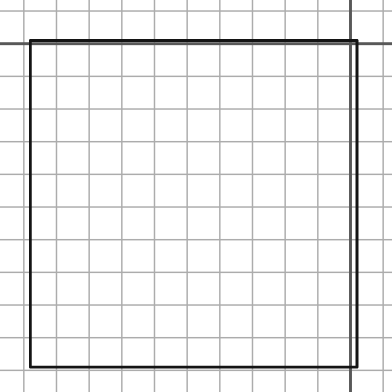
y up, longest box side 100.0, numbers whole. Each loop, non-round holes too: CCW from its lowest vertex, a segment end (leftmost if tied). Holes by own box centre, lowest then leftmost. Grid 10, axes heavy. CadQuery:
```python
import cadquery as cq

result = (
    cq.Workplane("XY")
    .moveTo(-98.0, -99.0)
    .lineTo(2.0, -99.0)
    .lineTo(2.0, 1.0)
    .lineTo(-98.0, 1.0)
    .close()
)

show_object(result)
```